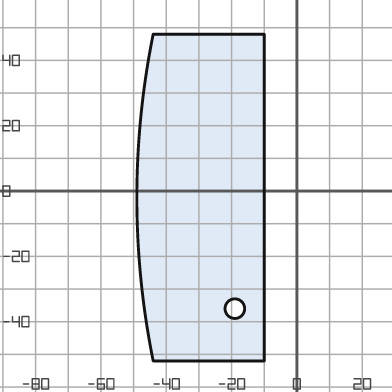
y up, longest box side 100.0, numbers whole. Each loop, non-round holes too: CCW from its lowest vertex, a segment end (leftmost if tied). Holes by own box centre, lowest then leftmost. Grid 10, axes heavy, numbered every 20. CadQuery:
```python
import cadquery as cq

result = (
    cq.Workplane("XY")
    .moveTo(-44.0, -52.0)
    .lineTo(-10.0, -52.0)
    .lineTo(-10.0, 48.0)
    .lineTo(-44.0, 48.0)
    .threePointArc((-49.0, -2.0), (-44.0, -52.0))
    .close()
    .moveTo(-19.0, -36.0)
    .circle(3.0)
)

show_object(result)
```